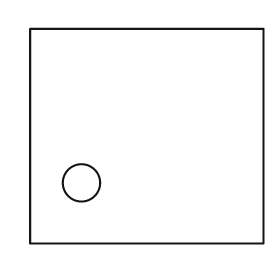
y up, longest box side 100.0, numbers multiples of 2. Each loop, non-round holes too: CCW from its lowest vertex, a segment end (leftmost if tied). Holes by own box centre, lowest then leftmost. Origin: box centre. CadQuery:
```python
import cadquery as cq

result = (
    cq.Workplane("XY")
    .moveTo(-50.0, -46.0)
    .lineTo(50.0, -46.0)
    .lineTo(50.0, 46.0)
    .lineTo(-50.0, 46.0)
    .close()
    .moveTo(-28.0, -20.0)
    .circle(8.0)
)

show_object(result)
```